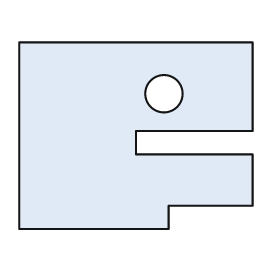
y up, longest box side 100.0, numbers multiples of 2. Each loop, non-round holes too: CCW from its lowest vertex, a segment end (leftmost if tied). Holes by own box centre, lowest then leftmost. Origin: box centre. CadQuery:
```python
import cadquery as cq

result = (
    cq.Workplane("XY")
    .moveTo(-50.0, -40.0)
    .lineTo(14.0, -40.0)
    .lineTo(14.0, -30.0)
    .lineTo(50.0, -30.0)
    .lineTo(50.0, -8.0)
    .lineTo(0.0, -8.0)
    .lineTo(0.0, 2.0)
    .lineTo(50.0, 2.0)
    .lineTo(50.0, 40.0)
    .lineTo(-50.0, 40.0)
    .close()
    .moveTo(12.0, 18.0)
    .circle(8.0)
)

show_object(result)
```